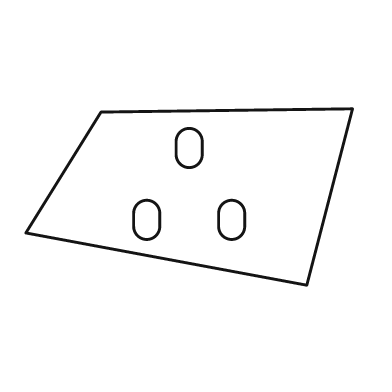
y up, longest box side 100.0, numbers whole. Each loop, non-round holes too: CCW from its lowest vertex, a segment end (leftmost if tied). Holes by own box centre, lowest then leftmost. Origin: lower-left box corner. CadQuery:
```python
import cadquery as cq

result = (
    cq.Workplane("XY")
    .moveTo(86.0, 0.0)
    .lineTo(100.0, 54.0)
    .lineTo(23.0, 53.0)
    .lineTo(0.0, 16.0)
    .close()
    .moveTo(33.0, 18.0)
    .threePointArc((37.0, 14.0), (41.0, 18.0))
    .lineTo(41.0, 22.0)
    .threePointArc((37.0, 26.0), (33.0, 22.0))
    .close()
    .moveTo(59.0, 18.0)
    .threePointArc((63.0, 14.0), (67.0, 18.0))
    .lineTo(67.0, 22.0)
    .threePointArc((63.0, 26.0), (59.0, 22.0))
    .close()
    .moveTo(46.0, 40.0)
    .threePointArc((50.0, 36.0), (54.0, 40.0))
    .lineTo(54.0, 44.0)
    .threePointArc((50.0, 48.0), (46.0, 44.0))
    .close()
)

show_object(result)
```